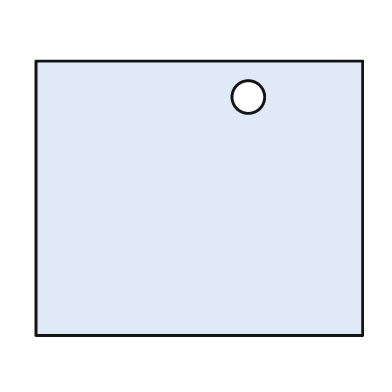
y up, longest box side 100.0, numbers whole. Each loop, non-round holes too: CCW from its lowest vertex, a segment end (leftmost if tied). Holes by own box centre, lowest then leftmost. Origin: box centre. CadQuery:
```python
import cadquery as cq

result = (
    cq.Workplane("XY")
    .moveTo(-50.0, -42.0)
    .lineTo(50.0, -42.0)
    .lineTo(50.0, 42.0)
    .lineTo(-50.0, 42.0)
    .close()
    .moveTo(15.0, 31.0)
    .circle(5.0)
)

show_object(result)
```